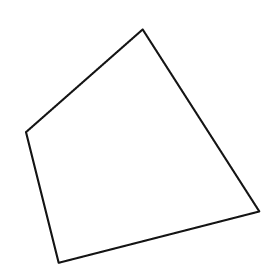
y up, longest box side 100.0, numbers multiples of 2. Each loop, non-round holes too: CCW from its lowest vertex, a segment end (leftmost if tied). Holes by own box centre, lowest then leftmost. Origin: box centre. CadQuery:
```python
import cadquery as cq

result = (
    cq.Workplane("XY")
    .moveTo(-36.0, -50.0)
    .lineTo(50.0, -28.0)
    .lineTo(0.0, 50.0)
    .lineTo(-50.0, 6.0)
    .close()
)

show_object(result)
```